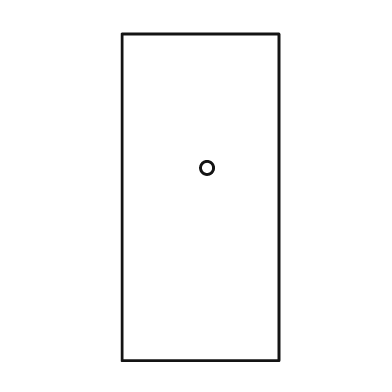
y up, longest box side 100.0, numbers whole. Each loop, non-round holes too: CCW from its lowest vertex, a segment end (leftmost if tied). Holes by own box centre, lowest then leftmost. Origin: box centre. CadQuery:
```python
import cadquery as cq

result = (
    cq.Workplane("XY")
    .moveTo(-24.0, -50.0)
    .lineTo(24.0, -50.0)
    .lineTo(24.0, 50.0)
    .lineTo(-24.0, 50.0)
    .close()
    .moveTo(2.0, 9.0)
    .circle(2.0)
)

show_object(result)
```